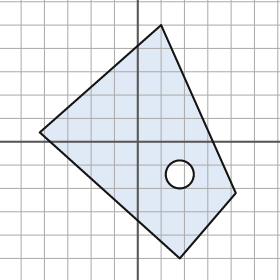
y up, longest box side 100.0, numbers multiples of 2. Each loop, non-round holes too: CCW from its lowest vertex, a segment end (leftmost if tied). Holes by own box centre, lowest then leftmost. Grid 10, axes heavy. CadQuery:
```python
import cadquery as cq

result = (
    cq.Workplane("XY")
    .moveTo(18.0, -50.0)
    .lineTo(42.0, -22.0)
    .lineTo(10.0, 50.0)
    .lineTo(-42.0, 4.0)
    .close()
    .moveTo(18.0, -14.0)
    .circle(6.0)
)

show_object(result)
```